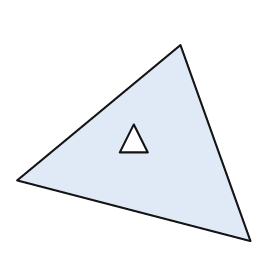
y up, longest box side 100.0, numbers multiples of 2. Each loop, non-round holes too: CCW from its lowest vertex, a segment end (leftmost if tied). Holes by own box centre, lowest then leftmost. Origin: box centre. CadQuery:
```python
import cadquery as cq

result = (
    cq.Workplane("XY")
    .moveTo(50.0, -42.0)
    .lineTo(20.0, 42.0)
    .lineTo(-50.0, -16.0)
    .close()
    .moveTo(-6.0, -4.0)
    .lineTo(6.0, -4.0)
    .lineTo(0.0, 8.0)
    .close()
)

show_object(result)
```